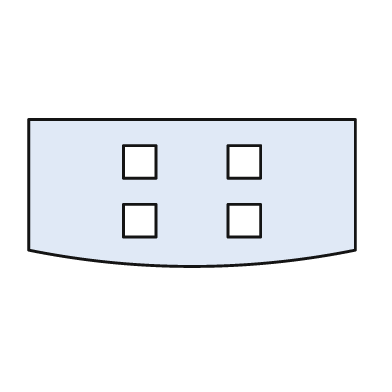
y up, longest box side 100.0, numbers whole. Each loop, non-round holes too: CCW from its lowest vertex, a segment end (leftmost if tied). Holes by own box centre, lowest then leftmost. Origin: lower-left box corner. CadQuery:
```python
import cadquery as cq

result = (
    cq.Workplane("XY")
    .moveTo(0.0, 5.0)
    .threePointArc((50.0, 0.0), (100.0, 5.0))
    .lineTo(100.0, 45.0)
    .lineTo(0.0, 45.0)
    .close()
    .moveTo(29.0, 9.0)
    .lineTo(39.0, 9.0)
    .lineTo(39.0, 19.0)
    .lineTo(29.0, 19.0)
    .close()
    .moveTo(61.0, 9.0)
    .lineTo(71.0, 9.0)
    .lineTo(71.0, 19.0)
    .lineTo(61.0, 19.0)
    .close()
    .moveTo(29.0, 27.0)
    .lineTo(39.0, 27.0)
    .lineTo(39.0, 37.0)
    .lineTo(29.0, 37.0)
    .close()
    .moveTo(61.0, 27.0)
    .lineTo(71.0, 27.0)
    .lineTo(71.0, 37.0)
    .lineTo(61.0, 37.0)
    .close()
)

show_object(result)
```